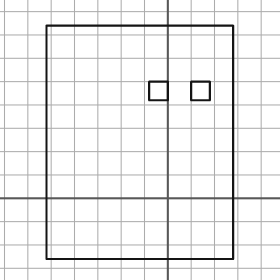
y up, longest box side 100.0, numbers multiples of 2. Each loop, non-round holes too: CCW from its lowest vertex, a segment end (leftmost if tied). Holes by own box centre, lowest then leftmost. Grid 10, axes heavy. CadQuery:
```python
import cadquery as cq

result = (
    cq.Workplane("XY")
    .moveTo(-52.0, -26.0)
    .lineTo(28.0, -26.0)
    .lineTo(28.0, 74.0)
    .lineTo(-52.0, 74.0)
    .close()
    .moveTo(-8.0, 42.0)
    .lineTo(0.0, 42.0)
    .lineTo(0.0, 50.0)
    .lineTo(-8.0, 50.0)
    .close()
    .moveTo(10.0, 42.0)
    .lineTo(18.0, 42.0)
    .lineTo(18.0, 50.0)
    .lineTo(10.0, 50.0)
    .close()
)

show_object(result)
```